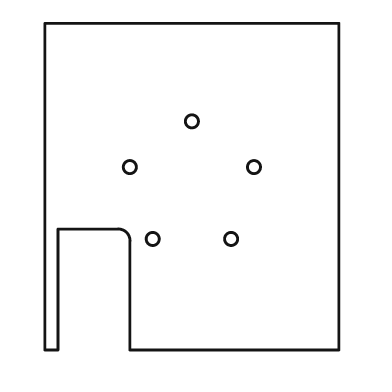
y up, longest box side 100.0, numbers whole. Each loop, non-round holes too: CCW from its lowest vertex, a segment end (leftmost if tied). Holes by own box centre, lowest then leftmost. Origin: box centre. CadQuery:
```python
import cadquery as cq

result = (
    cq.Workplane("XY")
    .moveTo(-45.0, -50.0)
    .lineTo(-41.0, -50.0)
    .lineTo(-41.0, -13.0)
    .lineTo(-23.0, -13.0)
    .threePointArc((-20.0, -14.0), (-19.0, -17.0))
    .lineTo(-19.0, -50.0)
    .lineTo(45.0, -50.0)
    .lineTo(45.0, 50.0)
    .lineTo(-45.0, 50.0)
    .close()
    .moveTo(-12.0, -16.0)
    .circle(2.0)
    .moveTo(12.0, -16.0)
    .circle(2.0)
    .moveTo(-19.0, 6.0)
    .circle(2.0)
    .moveTo(19.0, 6.0)
    .circle(2.0)
    .moveTo(0.0, 20.0)
    .circle(2.0)
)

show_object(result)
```